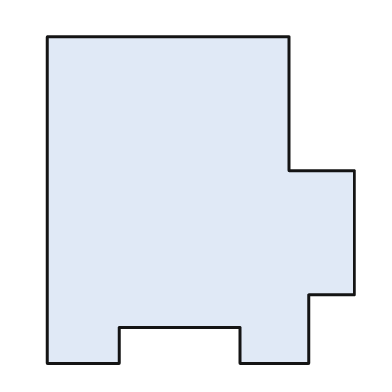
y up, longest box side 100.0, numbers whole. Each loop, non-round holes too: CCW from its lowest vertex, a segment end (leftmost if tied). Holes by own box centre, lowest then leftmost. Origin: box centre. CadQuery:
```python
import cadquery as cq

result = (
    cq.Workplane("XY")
    .moveTo(-47.0, -50.0)
    .lineTo(-25.0, -50.0)
    .lineTo(-25.0, -39.0)
    .lineTo(12.0, -39.0)
    .lineTo(12.0, -50.0)
    .lineTo(33.0, -50.0)
    .lineTo(33.0, -29.0)
    .lineTo(47.0, -29.0)
    .lineTo(47.0, 9.0)
    .lineTo(27.0, 9.0)
    .lineTo(27.0, 50.0)
    .lineTo(-47.0, 50.0)
    .close()
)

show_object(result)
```